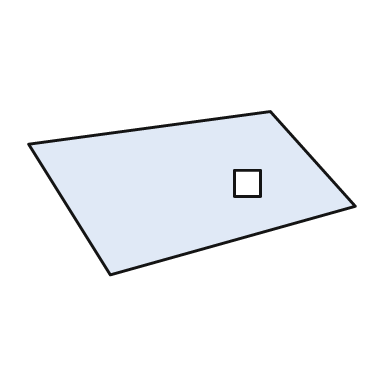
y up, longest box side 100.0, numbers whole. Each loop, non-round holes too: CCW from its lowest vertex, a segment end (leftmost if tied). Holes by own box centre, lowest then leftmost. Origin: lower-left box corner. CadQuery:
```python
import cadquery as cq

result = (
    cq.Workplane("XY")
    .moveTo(25.0, 0.0)
    .lineTo(100.0, 21.0)
    .lineTo(74.0, 50.0)
    .lineTo(0.0, 40.0)
    .close()
    .moveTo(63.0, 24.0)
    .lineTo(71.0, 24.0)
    .lineTo(71.0, 32.0)
    .lineTo(63.0, 32.0)
    .close()
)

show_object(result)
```